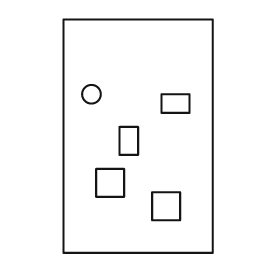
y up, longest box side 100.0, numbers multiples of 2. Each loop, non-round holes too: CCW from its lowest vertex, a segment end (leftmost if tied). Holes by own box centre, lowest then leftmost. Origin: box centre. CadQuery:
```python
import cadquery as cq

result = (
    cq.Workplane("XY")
    .moveTo(-32.0, -50.0)
    .lineTo(32.0, -50.0)
    .lineTo(32.0, 50.0)
    .lineTo(-32.0, 50.0)
    .close()
    .moveTo(6.0, -36.0)
    .lineTo(18.0, -36.0)
    .lineTo(18.0, -24.0)
    .lineTo(6.0, -24.0)
    .close()
    .moveTo(-18.0, -26.0)
    .lineTo(-6.0, -26.0)
    .lineTo(-6.0, -14.0)
    .lineTo(-18.0, -14.0)
    .close()
    .moveTo(-8.0, -8.0)
    .lineTo(0.0, -8.0)
    .lineTo(0.0, 4.0)
    .lineTo(-8.0, 4.0)
    .close()
    .moveTo(10.0, 10.0)
    .lineTo(22.0, 10.0)
    .lineTo(22.0, 18.0)
    .lineTo(10.0, 18.0)
    .close()
    .moveTo(-20.0, 18.0)
    .circle(4.0)
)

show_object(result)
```